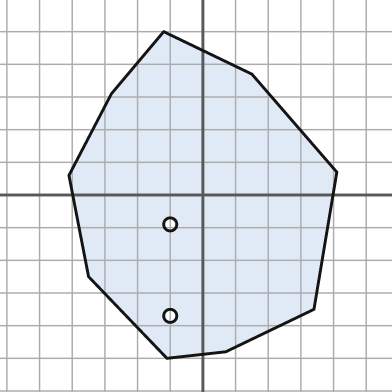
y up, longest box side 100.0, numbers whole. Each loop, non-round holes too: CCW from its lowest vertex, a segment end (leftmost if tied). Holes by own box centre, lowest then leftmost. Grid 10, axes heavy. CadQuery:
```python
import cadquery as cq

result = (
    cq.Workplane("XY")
    .moveTo(-11.0, -50.0)
    .lineTo(7.0, -48.0)
    .lineTo(34.0, -35.0)
    .lineTo(41.0, 7.0)
    .lineTo(15.0, 37.0)
    .lineTo(-12.0, 50.0)
    .lineTo(-28.0, 31.0)
    .lineTo(-41.0, 6.0)
    .lineTo(-35.0, -25.0)
    .close()
    .moveTo(-10.0, -37.0)
    .circle(2.0)
    .moveTo(-10.0, -9.0)
    .circle(2.0)
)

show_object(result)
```